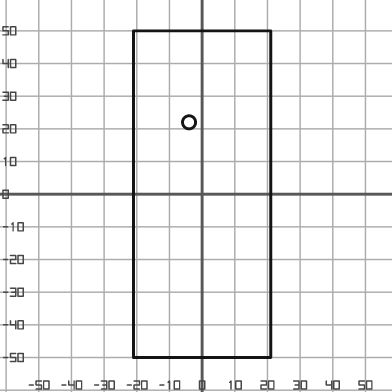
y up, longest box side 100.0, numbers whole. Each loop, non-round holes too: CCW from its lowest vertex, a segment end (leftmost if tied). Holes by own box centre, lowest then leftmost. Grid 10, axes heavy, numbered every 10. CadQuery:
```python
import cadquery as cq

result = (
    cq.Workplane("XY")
    .moveTo(-21.0, -50.0)
    .lineTo(21.0, -50.0)
    .lineTo(21.0, 50.0)
    .lineTo(-21.0, 50.0)
    .close()
    .moveTo(-4.0, 22.0)
    .circle(2.0)
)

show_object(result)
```